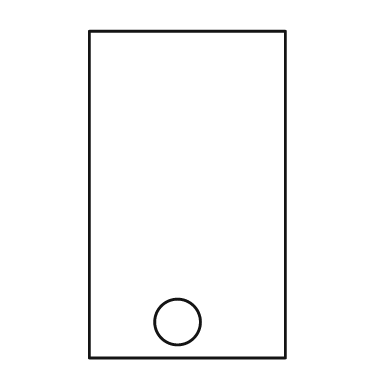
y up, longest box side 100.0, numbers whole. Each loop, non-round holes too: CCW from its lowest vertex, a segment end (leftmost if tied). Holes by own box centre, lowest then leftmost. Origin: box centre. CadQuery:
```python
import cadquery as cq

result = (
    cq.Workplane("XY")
    .moveTo(-30.0, -50.0)
    .lineTo(30.0, -50.0)
    .lineTo(30.0, 50.0)
    .lineTo(-30.0, 50.0)
    .close()
    .moveTo(-3.0, -39.0)
    .circle(7.0)
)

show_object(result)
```